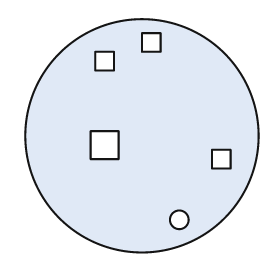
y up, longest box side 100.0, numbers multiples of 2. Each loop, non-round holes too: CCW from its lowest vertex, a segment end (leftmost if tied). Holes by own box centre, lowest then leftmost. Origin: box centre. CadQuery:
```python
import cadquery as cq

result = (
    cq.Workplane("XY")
    .moveTo(0.0, 0.0)
    .circle(50.0)
    .moveTo(16.0, -36.0)
    .circle(4.0)
    .moveTo(30.0, -14.0)
    .lineTo(38.0, -14.0)
    .lineTo(38.0, -6.0)
    .lineTo(30.0, -6.0)
    .close()
    .moveTo(-22.0, -10.0)
    .lineTo(-10.0, -10.0)
    .lineTo(-10.0, 2.0)
    .lineTo(-22.0, 2.0)
    .close()
    .moveTo(-20.0, 28.0)
    .lineTo(-12.0, 28.0)
    .lineTo(-12.0, 36.0)
    .lineTo(-20.0, 36.0)
    .close()
    .moveTo(0.0, 36.0)
    .lineTo(8.0, 36.0)
    .lineTo(8.0, 44.0)
    .lineTo(0.0, 44.0)
    .close()
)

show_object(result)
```